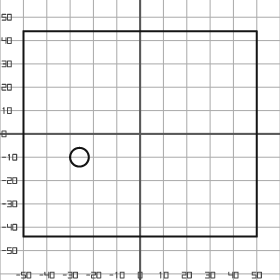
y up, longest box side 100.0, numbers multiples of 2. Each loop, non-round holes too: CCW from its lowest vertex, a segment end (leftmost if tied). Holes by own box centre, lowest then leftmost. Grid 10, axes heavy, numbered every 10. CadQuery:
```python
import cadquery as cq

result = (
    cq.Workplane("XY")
    .moveTo(-50.0, -44.0)
    .lineTo(50.0, -44.0)
    .lineTo(50.0, 44.0)
    .lineTo(-50.0, 44.0)
    .close()
    .moveTo(-26.0, -10.0)
    .circle(4.0)
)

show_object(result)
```